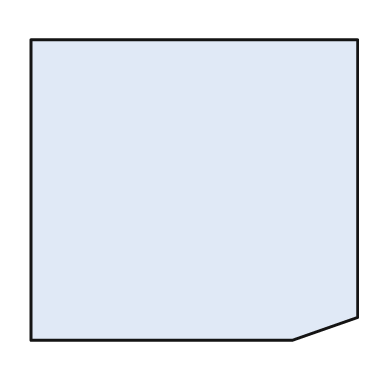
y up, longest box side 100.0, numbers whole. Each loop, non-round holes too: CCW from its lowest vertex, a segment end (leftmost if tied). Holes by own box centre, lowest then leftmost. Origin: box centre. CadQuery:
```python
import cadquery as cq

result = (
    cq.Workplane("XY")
    .moveTo(-50.0, -46.0)
    .lineTo(30.0, -46.0)
    .lineTo(50.0, -39.0)
    .lineTo(50.0, 46.0)
    .lineTo(-50.0, 46.0)
    .close()
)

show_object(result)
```